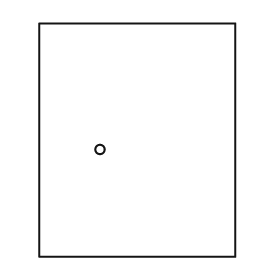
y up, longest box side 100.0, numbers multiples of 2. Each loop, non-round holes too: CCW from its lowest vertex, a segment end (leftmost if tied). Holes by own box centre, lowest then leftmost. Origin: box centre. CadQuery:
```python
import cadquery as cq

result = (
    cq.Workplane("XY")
    .moveTo(-42.0, -50.0)
    .lineTo(42.0, -50.0)
    .lineTo(42.0, 50.0)
    .lineTo(-42.0, 50.0)
    .close()
    .moveTo(-16.0, -4.0)
    .circle(2.0)
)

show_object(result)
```